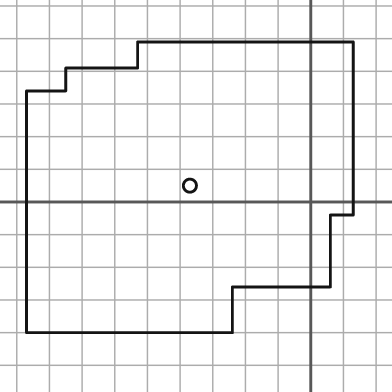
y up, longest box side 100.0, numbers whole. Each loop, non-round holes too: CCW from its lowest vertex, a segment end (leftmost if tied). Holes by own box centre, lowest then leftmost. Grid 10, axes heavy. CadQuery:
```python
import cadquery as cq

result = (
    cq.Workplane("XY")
    .moveTo(-87.0, -40.0)
    .lineTo(-24.0, -40.0)
    .lineTo(-24.0, -26.0)
    .lineTo(6.0, -26.0)
    .lineTo(6.0, -4.0)
    .lineTo(13.0, -4.0)
    .lineTo(13.0, 49.0)
    .lineTo(-53.0, 49.0)
    .lineTo(-53.0, 41.0)
    .lineTo(-75.0, 41.0)
    .lineTo(-75.0, 34.0)
    .lineTo(-87.0, 34.0)
    .close()
    .moveTo(-37.0, 5.0)
    .circle(2.0)
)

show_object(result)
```